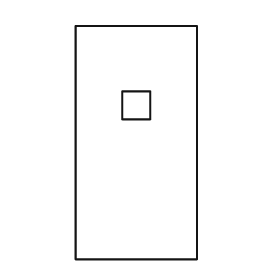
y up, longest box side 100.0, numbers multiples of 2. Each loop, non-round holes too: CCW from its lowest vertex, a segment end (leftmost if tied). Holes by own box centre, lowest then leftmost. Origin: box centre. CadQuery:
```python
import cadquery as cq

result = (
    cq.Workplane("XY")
    .moveTo(-26.0, -50.0)
    .lineTo(26.0, -50.0)
    .lineTo(26.0, 50.0)
    .lineTo(-26.0, 50.0)
    .close()
    .moveTo(-6.0, 10.0)
    .lineTo(6.0, 10.0)
    .lineTo(6.0, 22.0)
    .lineTo(-6.0, 22.0)
    .close()
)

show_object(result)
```